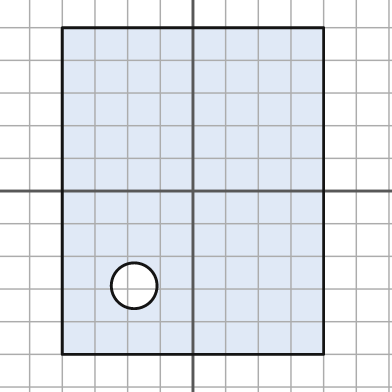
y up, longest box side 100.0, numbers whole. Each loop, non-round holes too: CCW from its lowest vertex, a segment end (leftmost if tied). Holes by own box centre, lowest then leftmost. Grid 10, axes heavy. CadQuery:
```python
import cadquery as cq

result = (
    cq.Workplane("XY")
    .moveTo(-40.0, -50.0)
    .lineTo(40.0, -50.0)
    .lineTo(40.0, 50.0)
    .lineTo(-40.0, 50.0)
    .close()
    .moveTo(-18.0, -29.0)
    .circle(7.0)
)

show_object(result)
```